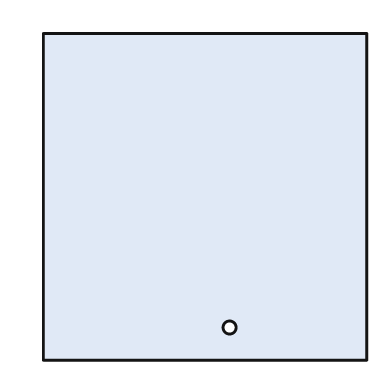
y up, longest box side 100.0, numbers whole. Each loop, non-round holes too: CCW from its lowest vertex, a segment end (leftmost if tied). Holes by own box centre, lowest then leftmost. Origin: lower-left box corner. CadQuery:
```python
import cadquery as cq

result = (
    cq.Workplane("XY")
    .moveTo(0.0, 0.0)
    .lineTo(99.0, 0.0)
    .lineTo(99.0, 100.0)
    .lineTo(0.0, 100.0)
    .close()
    .moveTo(57.0, 10.0)
    .circle(2.0)
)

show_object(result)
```